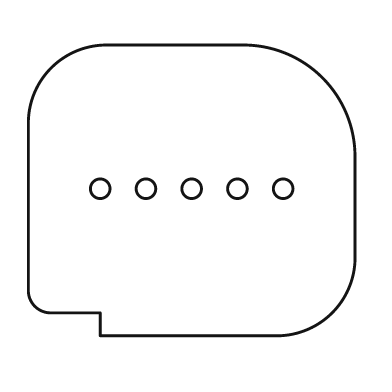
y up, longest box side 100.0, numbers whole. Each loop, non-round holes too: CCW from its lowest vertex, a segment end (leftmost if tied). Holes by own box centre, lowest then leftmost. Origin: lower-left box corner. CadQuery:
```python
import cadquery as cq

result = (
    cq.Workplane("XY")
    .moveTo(22.0, 0.0)
    .lineTo(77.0, 0.0)
    .threePointArc((93.0, 7.0), (100.0, 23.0))
    .lineTo(100.0, 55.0)
    .threePointArc((90.0, 79.0), (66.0, 89.0))
    .lineTo(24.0, 89.0)
    .threePointArc((7.0, 82.0), (0.0, 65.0))
    .lineTo(0.0, 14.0)
    .threePointArc((2.0, 9.0), (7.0, 7.0))
    .lineTo(22.0, 7.0)
    .close()
    .moveTo(22.0, 45.0)
    .circle(3.0)
    .moveTo(36.0, 45.0)
    .circle(3.0)
    .moveTo(50.0, 45.0)
    .circle(3.0)
    .moveTo(64.0, 45.0)
    .circle(3.0)
    .moveTo(78.0, 45.0)
    .circle(3.0)
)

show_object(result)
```